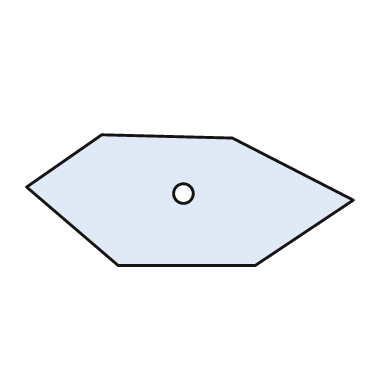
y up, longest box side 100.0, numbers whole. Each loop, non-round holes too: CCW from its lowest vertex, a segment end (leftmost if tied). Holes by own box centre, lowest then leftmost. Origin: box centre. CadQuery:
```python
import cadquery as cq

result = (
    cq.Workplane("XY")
    .moveTo(-22.0, -20.0)
    .lineTo(20.0, -20.0)
    .lineTo(50.0, 0.0)
    .lineTo(13.0, 19.0)
    .lineTo(-27.0, 20.0)
    .lineTo(-50.0, 4.0)
    .close()
    .moveTo(-2.0, 2.0)
    .circle(3.0)
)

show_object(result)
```